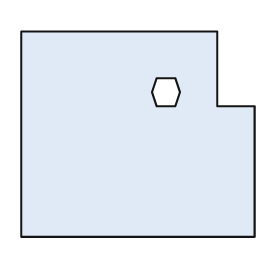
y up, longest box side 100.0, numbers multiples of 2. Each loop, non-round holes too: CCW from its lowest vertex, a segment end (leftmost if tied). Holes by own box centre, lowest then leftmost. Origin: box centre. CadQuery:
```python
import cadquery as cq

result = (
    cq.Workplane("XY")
    .moveTo(-50.0, -44.0)
    .lineTo(50.0, -44.0)
    .lineTo(50.0, 12.0)
    .lineTo(34.0, 12.0)
    .lineTo(34.0, 44.0)
    .lineTo(-50.0, 44.0)
    .close()
    .moveTo(8.0, 12.0)
    .lineTo(16.0, 12.0)
    .lineTo(18.0, 18.0)
    .lineTo(16.0, 24.0)
    .lineTo(8.0, 24.0)
    .lineTo(6.0, 18.0)
    .close()
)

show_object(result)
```